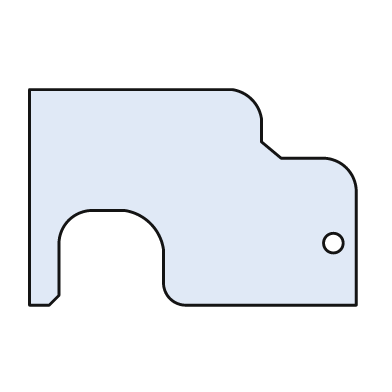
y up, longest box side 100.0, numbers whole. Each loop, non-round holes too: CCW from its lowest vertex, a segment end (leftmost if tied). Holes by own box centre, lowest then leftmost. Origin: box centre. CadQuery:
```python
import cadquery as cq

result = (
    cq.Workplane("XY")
    .moveTo(-50.0, -33.0)
    .lineTo(-44.0, -33.0)
    .lineTo(-41.0, -30.0)
    .lineTo(-41.0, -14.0)
    .threePointArc((-38.0, -7.0), (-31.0, -4.0))
    .lineTo(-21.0, -4.0)
    .threePointArc((-13.0, -8.0), (-9.0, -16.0))
    .lineTo(-9.0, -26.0)
    .threePointArc((-7.0, -31.0), (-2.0, -33.0))
    .lineTo(50.0, -33.0)
    .lineTo(50.0, 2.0)
    .threePointArc((47.0, 9.0), (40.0, 12.0))
    .lineTo(27.0, 12.0)
    .lineTo(21.0, 17.0)
    .lineTo(21.0, 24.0)
    .threePointArc((18.0, 30.0), (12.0, 33.0))
    .lineTo(-50.0, 33.0)
    .close()
    .moveTo(43.0, -14.0)
    .circle(3.0)
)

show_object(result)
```